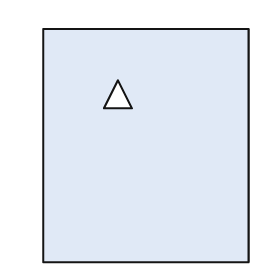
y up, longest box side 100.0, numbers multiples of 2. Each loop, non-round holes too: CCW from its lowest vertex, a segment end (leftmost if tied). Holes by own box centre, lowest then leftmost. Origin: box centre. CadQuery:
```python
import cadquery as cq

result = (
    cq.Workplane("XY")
    .moveTo(-44.0, -50.0)
    .lineTo(44.0, -50.0)
    .lineTo(44.0, 50.0)
    .lineTo(-44.0, 50.0)
    .close()
    .moveTo(-18.0, 16.0)
    .lineTo(-6.0, 16.0)
    .lineTo(-12.0, 28.0)
    .close()
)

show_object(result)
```